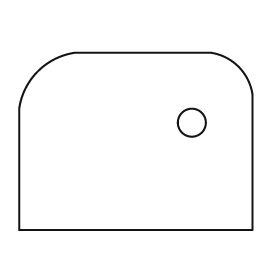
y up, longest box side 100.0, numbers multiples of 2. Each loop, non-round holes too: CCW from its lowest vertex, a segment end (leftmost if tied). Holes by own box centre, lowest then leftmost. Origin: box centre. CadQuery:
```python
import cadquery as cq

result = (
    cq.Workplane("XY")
    .moveTo(-50.0, -38.0)
    .lineTo(50.0, -38.0)
    .lineTo(50.0, 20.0)
    .threePointArc((44.0, 32.0), (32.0, 38.0))
    .lineTo(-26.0, 38.0)
    .threePointArc((-42.0, 30.0), (-50.0, 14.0))
    .close()
    .moveTo(24.0, 8.0)
    .circle(6.0)
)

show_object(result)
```